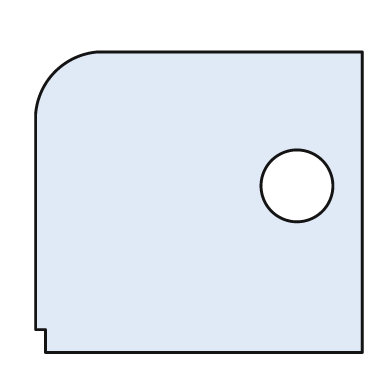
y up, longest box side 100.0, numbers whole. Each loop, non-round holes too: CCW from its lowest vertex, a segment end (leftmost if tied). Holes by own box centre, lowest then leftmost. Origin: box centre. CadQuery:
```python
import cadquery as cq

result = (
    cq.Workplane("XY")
    .moveTo(-47.0, -46.0)
    .lineTo(50.0, -46.0)
    .lineTo(50.0, 46.0)
    .lineTo(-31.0, 46.0)
    .threePointArc((-44.0, 40.0), (-50.0, 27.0))
    .lineTo(-50.0, -39.0)
    .lineTo(-47.0, -39.0)
    .close()
    .moveTo(30.0, 5.0)
    .circle(11.0)
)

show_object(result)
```